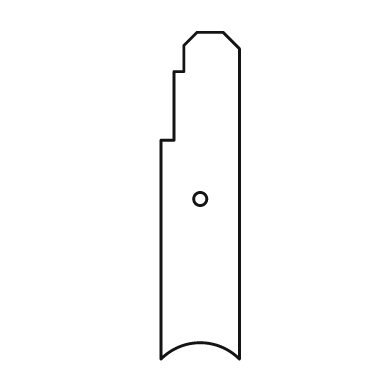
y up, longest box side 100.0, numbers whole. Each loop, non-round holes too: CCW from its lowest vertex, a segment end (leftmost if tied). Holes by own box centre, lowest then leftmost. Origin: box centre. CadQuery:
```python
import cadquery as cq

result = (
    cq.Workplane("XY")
    .moveTo(-12.0, -50.0)
    .threePointArc((0.0, -45.0), (12.0, -50.0))
    .lineTo(12.0, 45.0)
    .lineTo(7.0, 50.0)
    .lineTo(-1.0, 50.0)
    .lineTo(-5.0, 46.0)
    .lineTo(-5.0, 38.0)
    .lineTo(-8.0, 38.0)
    .lineTo(-8.0, 17.0)
    .lineTo(-12.0, 17.0)
    .close()
    .moveTo(0.0, -1.0)
    .circle(2.0)
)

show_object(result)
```